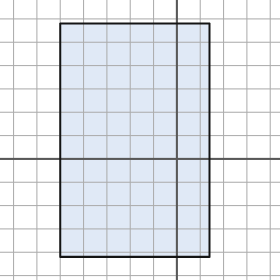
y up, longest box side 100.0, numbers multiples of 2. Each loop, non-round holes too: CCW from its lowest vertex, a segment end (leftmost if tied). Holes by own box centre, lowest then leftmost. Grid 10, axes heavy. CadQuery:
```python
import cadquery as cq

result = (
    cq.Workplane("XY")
    .moveTo(-50.0, -42.0)
    .lineTo(14.0, -42.0)
    .lineTo(14.0, 58.0)
    .lineTo(-50.0, 58.0)
    .close()
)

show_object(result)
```